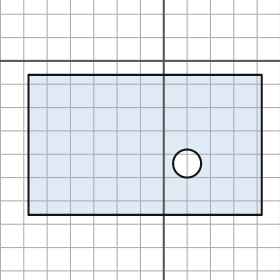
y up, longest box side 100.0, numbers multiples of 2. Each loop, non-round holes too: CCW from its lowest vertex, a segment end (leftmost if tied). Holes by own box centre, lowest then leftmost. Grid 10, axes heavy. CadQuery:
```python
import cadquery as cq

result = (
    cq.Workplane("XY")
    .moveTo(-58.0, -66.0)
    .lineTo(42.0, -66.0)
    .lineTo(42.0, -6.0)
    .lineTo(-58.0, -6.0)
    .close()
    .moveTo(10.0, -44.0)
    .circle(6.0)
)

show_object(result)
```